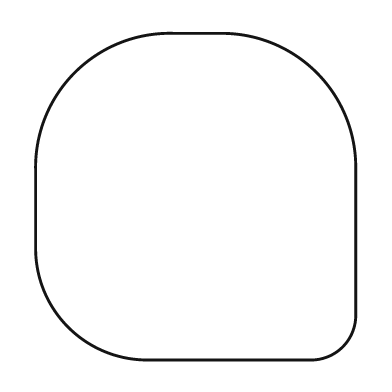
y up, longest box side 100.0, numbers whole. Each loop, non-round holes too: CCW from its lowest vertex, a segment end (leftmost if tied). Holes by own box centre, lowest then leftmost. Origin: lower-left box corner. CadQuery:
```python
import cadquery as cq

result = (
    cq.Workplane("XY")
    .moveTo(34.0, 0.0)
    .lineTo(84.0, 0.0)
    .threePointArc((94.0, 4.0), (98.0, 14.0))
    .lineTo(98.0, 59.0)
    .threePointArc((86.0, 88.0), (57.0, 100.0))
    .lineTo(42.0, 100.0)
    .threePointArc((12.0, 88.0), (0.0, 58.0))
    .lineTo(0.0, 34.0)
    .threePointArc((10.0, 10.0), (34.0, 0.0))
    .close()
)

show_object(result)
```